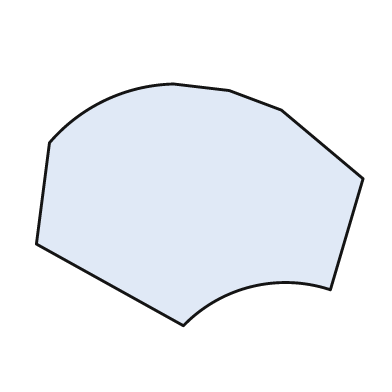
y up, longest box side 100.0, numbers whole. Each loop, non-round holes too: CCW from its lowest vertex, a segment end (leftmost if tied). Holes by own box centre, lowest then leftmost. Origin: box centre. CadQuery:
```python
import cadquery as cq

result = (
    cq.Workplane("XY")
    .moveTo(-5.0, -37.0)
    .threePointArc((16.0, -25.0), (40.0, -26.0))
    .lineTo(50.0, 8.0)
    .lineTo(25.0, 29.0)
    .lineTo(9.0, 35.0)
    .lineTo(-8.0, 37.0)
    .threePointArc((-29.0, 32.0), (-46.0, 19.0))
    .lineTo(-50.0, -12.0)
    .close()
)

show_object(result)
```